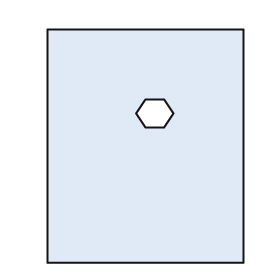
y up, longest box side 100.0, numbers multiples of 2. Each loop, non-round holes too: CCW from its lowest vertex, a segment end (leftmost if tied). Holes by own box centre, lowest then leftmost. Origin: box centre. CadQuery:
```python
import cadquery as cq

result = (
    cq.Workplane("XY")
    .moveTo(-42.0, -50.0)
    .lineTo(42.0, -50.0)
    .lineTo(42.0, 50.0)
    .lineTo(-42.0, 50.0)
    .close()
    .moveTo(0.0, 8.0)
    .lineTo(8.0, 8.0)
    .lineTo(12.0, 14.0)
    .lineTo(8.0, 20.0)
    .lineTo(0.0, 20.0)
    .lineTo(-4.0, 14.0)
    .close()
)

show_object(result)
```